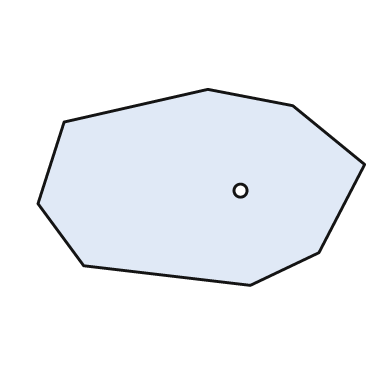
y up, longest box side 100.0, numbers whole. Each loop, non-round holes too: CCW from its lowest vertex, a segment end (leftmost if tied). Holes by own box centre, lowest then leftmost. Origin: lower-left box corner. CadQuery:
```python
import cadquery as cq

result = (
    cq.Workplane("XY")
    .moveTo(65.0, 0.0)
    .lineTo(86.0, 10.0)
    .lineTo(100.0, 37.0)
    .lineTo(78.0, 55.0)
    .lineTo(52.0, 60.0)
    .lineTo(8.0, 50.0)
    .lineTo(0.0, 25.0)
    .lineTo(14.0, 6.0)
    .close()
    .moveTo(62.0, 29.0)
    .circle(2.0)
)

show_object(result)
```